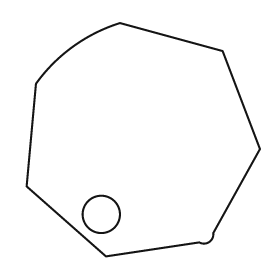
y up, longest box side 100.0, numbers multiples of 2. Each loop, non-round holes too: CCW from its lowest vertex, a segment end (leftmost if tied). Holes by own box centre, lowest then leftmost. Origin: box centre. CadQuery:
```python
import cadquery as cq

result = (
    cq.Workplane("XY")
    .moveTo(-16.0, -50.0)
    .lineTo(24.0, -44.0)
    .threePointArc((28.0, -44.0), (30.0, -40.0))
    .lineTo(50.0, -4.0)
    .lineTo(34.0, 38.0)
    .lineTo(-10.0, 50.0)
    .threePointArc((-30.0, 40.0), (-46.0, 24.0))
    .lineTo(-50.0, -20.0)
    .close()
    .moveTo(-18.0, -32.0)
    .circle(8.0)
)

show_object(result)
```